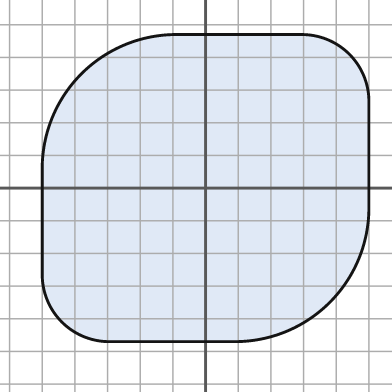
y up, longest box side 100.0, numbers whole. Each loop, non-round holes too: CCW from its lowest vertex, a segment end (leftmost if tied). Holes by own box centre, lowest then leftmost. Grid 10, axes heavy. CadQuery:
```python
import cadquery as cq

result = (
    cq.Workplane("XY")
    .moveTo(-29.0, -47.0)
    .lineTo(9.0, -47.0)
    .threePointArc((38.0, -35.0), (50.0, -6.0))
    .lineTo(50.0, 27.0)
    .threePointArc((44.0, 41.0), (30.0, 47.0))
    .lineTo(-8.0, 47.0)
    .threePointArc((-38.0, 35.0), (-50.0, 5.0))
    .lineTo(-50.0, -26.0)
    .threePointArc((-44.0, -41.0), (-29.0, -47.0))
    .close()
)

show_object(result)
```